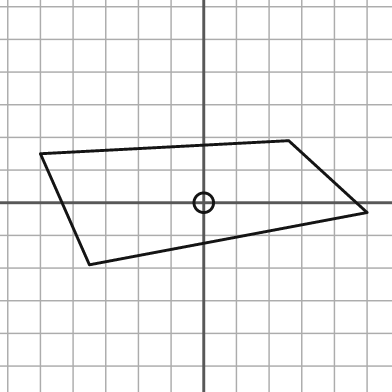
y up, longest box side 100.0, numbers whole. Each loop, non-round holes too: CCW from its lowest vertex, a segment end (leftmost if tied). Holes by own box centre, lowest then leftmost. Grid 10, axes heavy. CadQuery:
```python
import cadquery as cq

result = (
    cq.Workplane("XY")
    .moveTo(-35.0, -19.0)
    .lineTo(50.0, -3.0)
    .lineTo(26.0, 19.0)
    .lineTo(-50.0, 15.0)
    .close()
    .moveTo(0.0, 0.0)
    .circle(3.0)
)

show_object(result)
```